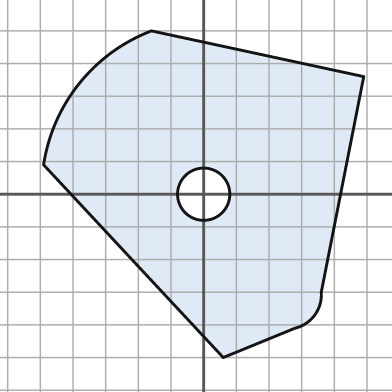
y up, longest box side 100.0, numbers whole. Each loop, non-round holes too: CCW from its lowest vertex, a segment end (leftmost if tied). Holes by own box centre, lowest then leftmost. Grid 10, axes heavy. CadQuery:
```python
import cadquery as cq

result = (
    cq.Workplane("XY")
    .moveTo(6.0, -50.0)
    .lineTo(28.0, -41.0)
    .threePointArc((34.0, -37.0), (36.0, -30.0))
    .lineTo(49.0, 36.0)
    .lineTo(-16.0, 50.0)
    .threePointArc((-38.0, 34.0), (-49.0, 9.0))
    .close()
    .moveTo(0.0, 0.0)
    .circle(8.0)
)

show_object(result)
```